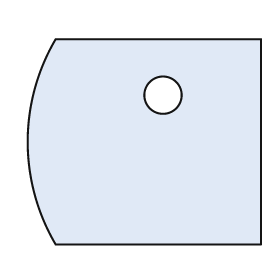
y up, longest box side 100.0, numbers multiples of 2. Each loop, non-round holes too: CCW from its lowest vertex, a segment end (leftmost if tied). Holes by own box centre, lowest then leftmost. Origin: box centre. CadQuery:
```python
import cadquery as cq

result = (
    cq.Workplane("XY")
    .moveTo(-38.0, -44.0)
    .lineTo(50.0, -44.0)
    .lineTo(50.0, 44.0)
    .lineTo(-38.0, 44.0)
    .threePointArc((-50.0, 0.0), (-38.0, -44.0))
    .close()
    .moveTo(8.0, 20.0)
    .circle(8.0)
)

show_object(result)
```